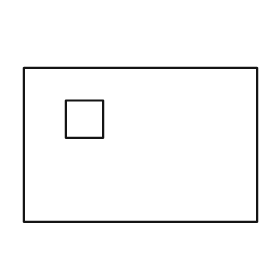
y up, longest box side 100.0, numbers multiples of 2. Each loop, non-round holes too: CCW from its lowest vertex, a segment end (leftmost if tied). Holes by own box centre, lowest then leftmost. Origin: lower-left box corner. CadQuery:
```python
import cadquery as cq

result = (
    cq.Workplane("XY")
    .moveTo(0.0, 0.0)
    .lineTo(100.0, 0.0)
    .lineTo(100.0, 66.0)
    .lineTo(0.0, 66.0)
    .close()
    .moveTo(18.0, 36.0)
    .lineTo(34.0, 36.0)
    .lineTo(34.0, 52.0)
    .lineTo(18.0, 52.0)
    .close()
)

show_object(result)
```